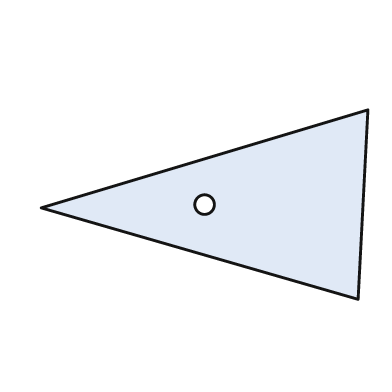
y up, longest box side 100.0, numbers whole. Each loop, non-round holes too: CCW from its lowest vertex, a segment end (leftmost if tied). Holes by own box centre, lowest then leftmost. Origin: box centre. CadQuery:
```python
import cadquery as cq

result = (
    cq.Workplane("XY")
    .moveTo(47.0, -29.0)
    .lineTo(50.0, 29.0)
    .lineTo(-50.0, -1.0)
    .close()
    .moveTo(0.0, 0.0)
    .circle(3.0)
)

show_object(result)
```